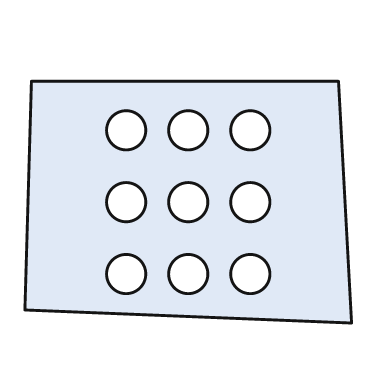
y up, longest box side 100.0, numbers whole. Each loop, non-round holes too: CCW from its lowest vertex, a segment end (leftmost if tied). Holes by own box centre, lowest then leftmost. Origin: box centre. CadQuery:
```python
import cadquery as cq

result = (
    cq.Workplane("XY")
    .moveTo(50.0, -37.0)
    .lineTo(46.0, 37.0)
    .lineTo(-48.0, 37.0)
    .lineTo(-50.0, -33.0)
    .close()
    .moveTo(-19.0, -22.0)
    .circle(6.0)
    .moveTo(0.0, -22.0)
    .circle(6.0)
    .moveTo(19.0, -22.0)
    .circle(6.0)
    .moveTo(-19.0, 0.0)
    .circle(6.0)
    .moveTo(0.0, 0.0)
    .circle(6.0)
    .moveTo(19.0, 0.0)
    .circle(6.0)
    .moveTo(-19.0, 22.0)
    .circle(6.0)
    .moveTo(0.0, 22.0)
    .circle(6.0)
    .moveTo(19.0, 22.0)
    .circle(6.0)
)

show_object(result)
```